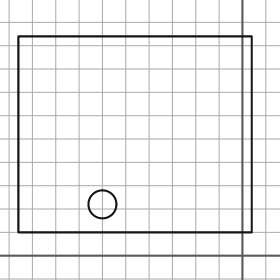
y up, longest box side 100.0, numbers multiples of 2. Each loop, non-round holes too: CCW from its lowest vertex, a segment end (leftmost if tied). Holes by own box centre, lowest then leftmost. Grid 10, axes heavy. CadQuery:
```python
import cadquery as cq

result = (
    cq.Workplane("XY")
    .moveTo(-96.0, 10.0)
    .lineTo(4.0, 10.0)
    .lineTo(4.0, 94.0)
    .lineTo(-96.0, 94.0)
    .close()
    .moveTo(-60.0, 22.0)
    .circle(6.0)
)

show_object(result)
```